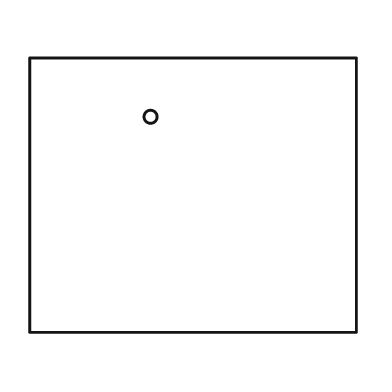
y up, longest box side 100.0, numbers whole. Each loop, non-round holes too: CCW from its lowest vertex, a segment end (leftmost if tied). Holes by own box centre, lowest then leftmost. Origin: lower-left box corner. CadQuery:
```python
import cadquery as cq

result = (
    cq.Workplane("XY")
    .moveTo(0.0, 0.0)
    .lineTo(100.0, 0.0)
    .lineTo(100.0, 84.0)
    .lineTo(0.0, 84.0)
    .close()
    .moveTo(37.0, 66.0)
    .circle(2.0)
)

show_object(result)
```